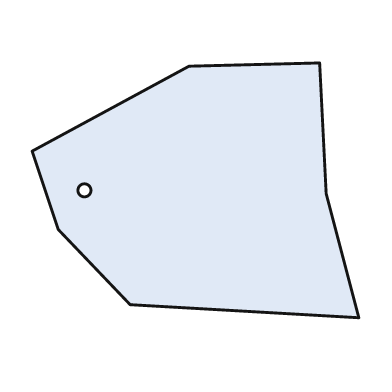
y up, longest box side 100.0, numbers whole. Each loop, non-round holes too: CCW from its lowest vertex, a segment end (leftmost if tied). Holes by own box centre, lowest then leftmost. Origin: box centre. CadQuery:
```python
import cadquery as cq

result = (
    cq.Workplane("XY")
    .moveTo(50.0, -39.0)
    .lineTo(40.0, -1.0)
    .lineTo(38.0, 39.0)
    .lineTo(-2.0, 38.0)
    .lineTo(-50.0, 12.0)
    .lineTo(-42.0, -12.0)
    .lineTo(-20.0, -35.0)
    .close()
    .moveTo(-34.0, 0.0)
    .circle(2.0)
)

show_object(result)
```